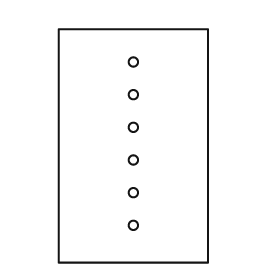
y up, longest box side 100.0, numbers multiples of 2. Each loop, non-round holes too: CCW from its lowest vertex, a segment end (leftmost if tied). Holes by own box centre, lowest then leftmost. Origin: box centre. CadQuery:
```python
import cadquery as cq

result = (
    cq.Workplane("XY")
    .moveTo(-32.0, -50.0)
    .lineTo(32.0, -50.0)
    .lineTo(32.0, 50.0)
    .lineTo(-32.0, 50.0)
    .close()
    .moveTo(0.0, -34.0)
    .circle(2.0)
    .moveTo(0.0, -20.0)
    .circle(2.0)
    .moveTo(0.0, -6.0)
    .circle(2.0)
    .moveTo(0.0, 8.0)
    .circle(2.0)
    .moveTo(0.0, 22.0)
    .circle(2.0)
    .moveTo(0.0, 36.0)
    .circle(2.0)
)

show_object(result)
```